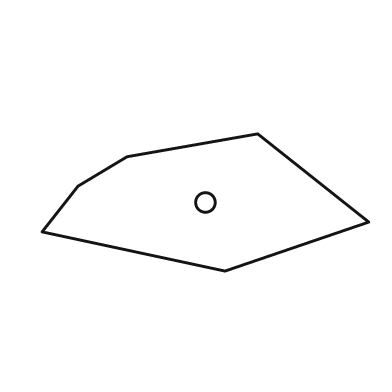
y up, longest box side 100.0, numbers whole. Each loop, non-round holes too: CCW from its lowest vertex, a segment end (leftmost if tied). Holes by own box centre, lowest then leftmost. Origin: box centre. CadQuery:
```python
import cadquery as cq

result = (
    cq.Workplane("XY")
    .moveTo(6.0, -21.0)
    .lineTo(50.0, -6.0)
    .lineTo(16.0, 21.0)
    .lineTo(-24.0, 14.0)
    .lineTo(-39.0, 5.0)
    .lineTo(-50.0, -9.0)
    .close()
    .moveTo(0.0, 0.0)
    .circle(3.0)
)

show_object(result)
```